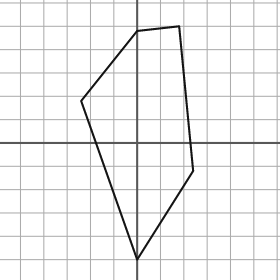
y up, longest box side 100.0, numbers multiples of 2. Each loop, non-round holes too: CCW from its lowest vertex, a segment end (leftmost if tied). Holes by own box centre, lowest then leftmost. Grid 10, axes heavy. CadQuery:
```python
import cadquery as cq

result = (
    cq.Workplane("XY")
    .moveTo(0.0, -50.0)
    .lineTo(24.0, -12.0)
    .lineTo(18.0, 50.0)
    .lineTo(0.0, 48.0)
    .lineTo(-24.0, 18.0)
    .close()
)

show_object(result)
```